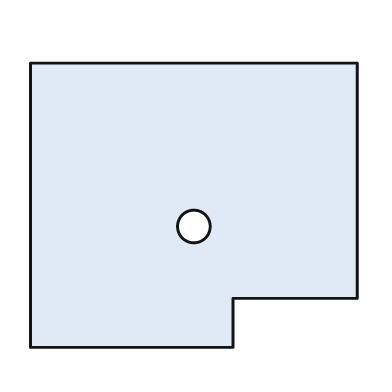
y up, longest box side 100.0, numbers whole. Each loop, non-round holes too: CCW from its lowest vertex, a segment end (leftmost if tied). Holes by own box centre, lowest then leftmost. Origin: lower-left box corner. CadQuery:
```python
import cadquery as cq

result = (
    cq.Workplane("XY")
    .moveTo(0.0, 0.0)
    .lineTo(62.0, 0.0)
    .lineTo(62.0, 15.0)
    .lineTo(100.0, 15.0)
    .lineTo(100.0, 87.0)
    .lineTo(0.0, 87.0)
    .close()
    .moveTo(50.0, 37.0)
    .circle(5.0)
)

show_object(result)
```